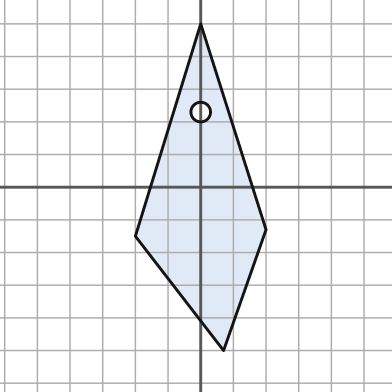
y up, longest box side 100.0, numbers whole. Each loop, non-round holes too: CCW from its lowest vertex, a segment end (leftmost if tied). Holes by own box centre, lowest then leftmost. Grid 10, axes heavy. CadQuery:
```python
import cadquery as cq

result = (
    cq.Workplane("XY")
    .moveTo(7.0, -50.0)
    .lineTo(20.0, -13.0)
    .lineTo(0.0, 50.0)
    .lineTo(-20.0, -15.0)
    .close()
    .moveTo(0.0, 23.0)
    .circle(3.0)
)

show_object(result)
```